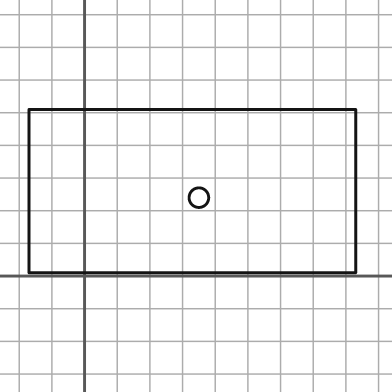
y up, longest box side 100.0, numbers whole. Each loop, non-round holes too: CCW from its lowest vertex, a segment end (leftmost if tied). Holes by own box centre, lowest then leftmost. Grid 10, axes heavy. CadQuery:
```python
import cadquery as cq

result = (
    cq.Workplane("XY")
    .moveTo(-17.0, 1.0)
    .lineTo(83.0, 1.0)
    .lineTo(83.0, 51.0)
    .lineTo(-17.0, 51.0)
    .close()
    .moveTo(35.0, 24.0)
    .circle(3.0)
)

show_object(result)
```